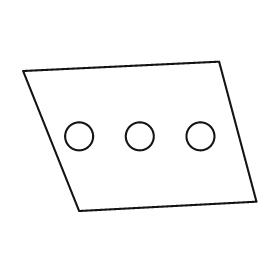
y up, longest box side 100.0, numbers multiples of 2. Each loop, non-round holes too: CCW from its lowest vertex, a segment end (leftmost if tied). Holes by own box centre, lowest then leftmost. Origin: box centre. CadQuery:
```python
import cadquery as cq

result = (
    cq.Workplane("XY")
    .moveTo(-26.0, -32.0)
    .lineTo(50.0, -28.0)
    .lineTo(34.0, 32.0)
    .lineTo(-50.0, 28.0)
    .close()
    .moveTo(-26.0, 0.0)
    .circle(6.0)
    .moveTo(0.0, 0.0)
    .circle(6.0)
    .moveTo(26.0, 0.0)
    .circle(6.0)
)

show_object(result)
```